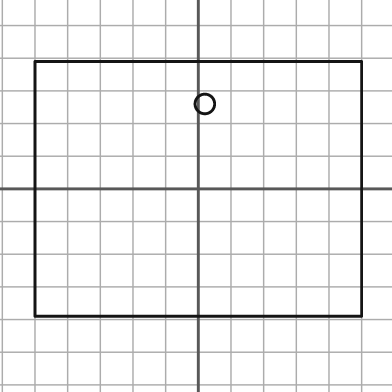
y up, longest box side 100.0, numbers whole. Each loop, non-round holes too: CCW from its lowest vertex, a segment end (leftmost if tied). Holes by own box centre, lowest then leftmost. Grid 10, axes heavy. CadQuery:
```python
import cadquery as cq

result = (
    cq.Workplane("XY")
    .moveTo(-50.0, -39.0)
    .lineTo(50.0, -39.0)
    .lineTo(50.0, 39.0)
    .lineTo(-50.0, 39.0)
    .close()
    .moveTo(2.0, 26.0)
    .circle(3.0)
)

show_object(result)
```